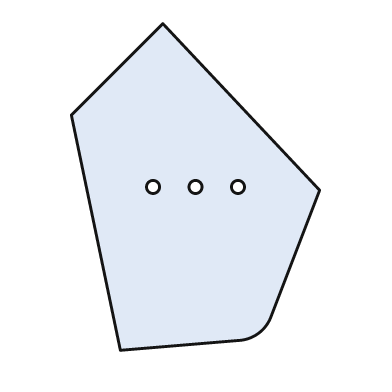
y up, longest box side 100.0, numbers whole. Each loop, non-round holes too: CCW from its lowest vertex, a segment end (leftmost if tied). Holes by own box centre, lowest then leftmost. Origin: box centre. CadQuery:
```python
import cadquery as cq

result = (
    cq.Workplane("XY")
    .moveTo(-23.0, -50.0)
    .lineTo(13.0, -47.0)
    .threePointArc((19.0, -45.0), (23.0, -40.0))
    .lineTo(38.0, -1.0)
    .lineTo(-10.0, 50.0)
    .lineTo(-38.0, 22.0)
    .close()
    .moveTo(-13.0, 0.0)
    .circle(2.0)
    .moveTo(0.0, 0.0)
    .circle(2.0)
    .moveTo(13.0, 0.0)
    .circle(2.0)
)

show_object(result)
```